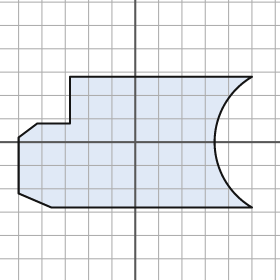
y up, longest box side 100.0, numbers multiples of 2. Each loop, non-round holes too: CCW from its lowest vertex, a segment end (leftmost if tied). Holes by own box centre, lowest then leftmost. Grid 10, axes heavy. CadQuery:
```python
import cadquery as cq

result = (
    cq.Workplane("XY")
    .moveTo(-36.0, -28.0)
    .lineTo(50.0, -28.0)
    .threePointArc((34.0, 0.0), (50.0, 28.0))
    .lineTo(-28.0, 28.0)
    .lineTo(-28.0, 8.0)
    .lineTo(-42.0, 8.0)
    .lineTo(-50.0, 2.0)
    .lineTo(-50.0, -22.0)
    .close()
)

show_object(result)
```